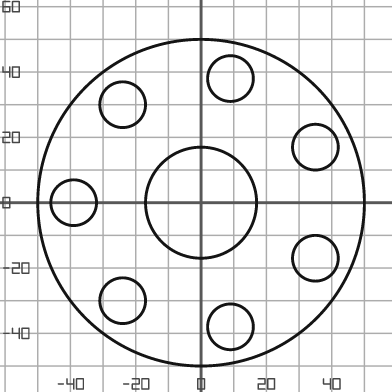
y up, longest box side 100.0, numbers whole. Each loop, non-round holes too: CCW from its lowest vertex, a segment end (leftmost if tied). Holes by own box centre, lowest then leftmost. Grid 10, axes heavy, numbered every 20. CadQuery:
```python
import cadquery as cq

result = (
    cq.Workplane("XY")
    .moveTo(0.0, 0.0)
    .circle(50.0)
    .moveTo(9.0, -38.0)
    .circle(7.0)
    .moveTo(-24.0, -30.0)
    .circle(7.0)
    .moveTo(35.0, -17.0)
    .circle(7.0)
    .moveTo(-39.0, 0.0)
    .circle(7.0)
    .moveTo(0.0, 0.0)
    .circle(17.0)
    .moveTo(35.0, 17.0)
    .circle(7.0)
    .moveTo(-24.0, 30.0)
    .circle(7.0)
    .moveTo(9.0, 38.0)
    .circle(7.0)
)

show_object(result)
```